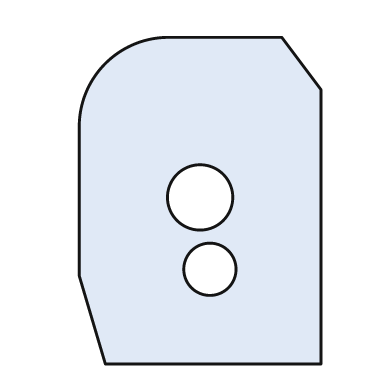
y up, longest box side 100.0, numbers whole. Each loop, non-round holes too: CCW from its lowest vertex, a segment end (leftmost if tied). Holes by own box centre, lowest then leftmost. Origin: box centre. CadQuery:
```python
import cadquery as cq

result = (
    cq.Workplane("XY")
    .moveTo(-29.0, -50.0)
    .lineTo(37.0, -50.0)
    .lineTo(37.0, 34.0)
    .lineTo(25.0, 50.0)
    .lineTo(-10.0, 50.0)
    .threePointArc((-29.0, 42.0), (-37.0, 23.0))
    .lineTo(-37.0, -23.0)
    .close()
    .moveTo(3.0, -21.0)
    .circle(8.0)
    .moveTo(0.0, 1.0)
    .circle(10.0)
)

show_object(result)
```